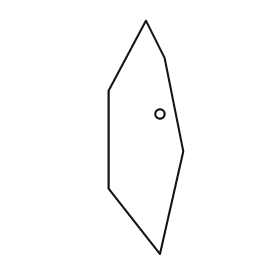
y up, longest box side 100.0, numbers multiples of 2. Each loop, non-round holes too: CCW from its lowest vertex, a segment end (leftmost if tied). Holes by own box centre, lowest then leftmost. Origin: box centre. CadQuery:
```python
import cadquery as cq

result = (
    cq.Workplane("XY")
    .moveTo(6.0, -50.0)
    .lineTo(16.0, -6.0)
    .lineTo(8.0, 34.0)
    .lineTo(0.0, 50.0)
    .lineTo(-16.0, 20.0)
    .lineTo(-16.0, -22.0)
    .close()
    .moveTo(6.0, 10.0)
    .circle(2.0)
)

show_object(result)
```